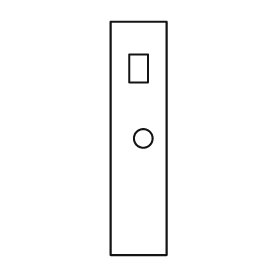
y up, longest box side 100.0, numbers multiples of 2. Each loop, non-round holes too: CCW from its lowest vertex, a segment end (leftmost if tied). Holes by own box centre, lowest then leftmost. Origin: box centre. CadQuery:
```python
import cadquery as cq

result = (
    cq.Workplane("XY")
    .moveTo(-12.0, -50.0)
    .lineTo(12.0, -50.0)
    .lineTo(12.0, 50.0)
    .lineTo(-12.0, 50.0)
    .close()
    .moveTo(2.0, 0.0)
    .circle(4.0)
    .moveTo(-4.0, 24.0)
    .lineTo(4.0, 24.0)
    .lineTo(4.0, 36.0)
    .lineTo(-4.0, 36.0)
    .close()
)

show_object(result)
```